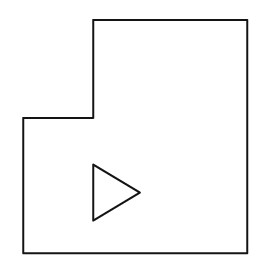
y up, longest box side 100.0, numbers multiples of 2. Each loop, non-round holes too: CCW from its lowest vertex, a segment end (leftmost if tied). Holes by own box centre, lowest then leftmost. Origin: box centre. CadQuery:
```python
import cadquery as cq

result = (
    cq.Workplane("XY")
    .moveTo(-48.0, -50.0)
    .lineTo(48.0, -50.0)
    .lineTo(48.0, 50.0)
    .lineTo(-18.0, 50.0)
    .lineTo(-18.0, 8.0)
    .lineTo(-48.0, 8.0)
    .close()
    .moveTo(-18.0, -36.0)
    .lineTo(2.0, -24.0)
    .lineTo(-18.0, -12.0)
    .close()
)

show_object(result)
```